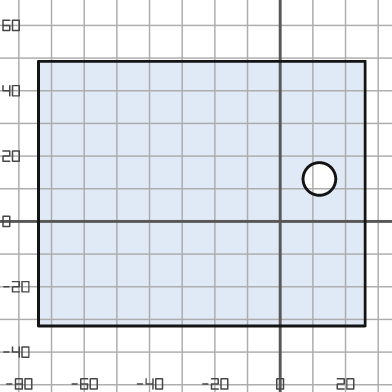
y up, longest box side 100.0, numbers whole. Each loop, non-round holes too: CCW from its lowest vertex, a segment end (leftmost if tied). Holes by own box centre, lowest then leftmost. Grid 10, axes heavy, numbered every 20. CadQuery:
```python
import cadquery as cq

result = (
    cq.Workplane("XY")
    .moveTo(-74.0, -32.0)
    .lineTo(26.0, -32.0)
    .lineTo(26.0, 49.0)
    .lineTo(-74.0, 49.0)
    .close()
    .moveTo(12.0, 13.0)
    .circle(5.0)
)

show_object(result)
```